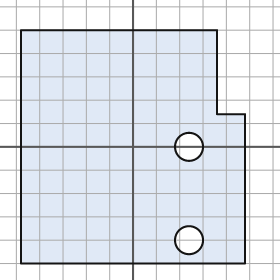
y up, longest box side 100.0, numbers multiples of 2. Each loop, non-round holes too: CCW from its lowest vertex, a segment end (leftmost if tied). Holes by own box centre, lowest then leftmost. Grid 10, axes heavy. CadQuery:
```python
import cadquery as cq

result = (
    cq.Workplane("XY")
    .moveTo(-48.0, -50.0)
    .lineTo(48.0, -50.0)
    .lineTo(48.0, 14.0)
    .lineTo(36.0, 14.0)
    .lineTo(36.0, 50.0)
    .lineTo(-48.0, 50.0)
    .close()
    .moveTo(24.0, -40.0)
    .circle(6.0)
    .moveTo(24.0, 0.0)
    .circle(6.0)
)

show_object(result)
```